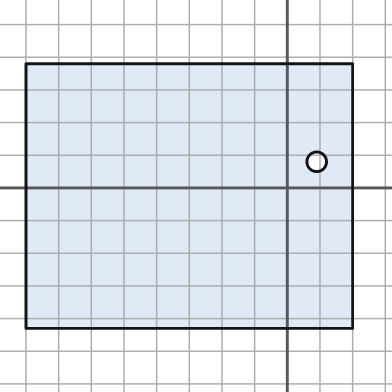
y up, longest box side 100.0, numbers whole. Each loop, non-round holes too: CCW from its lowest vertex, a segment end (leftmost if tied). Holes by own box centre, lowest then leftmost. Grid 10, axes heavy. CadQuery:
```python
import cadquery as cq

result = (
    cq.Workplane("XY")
    .moveTo(-80.0, -43.0)
    .lineTo(20.0, -43.0)
    .lineTo(20.0, 38.0)
    .lineTo(-80.0, 38.0)
    .close()
    .moveTo(9.0, 8.0)
    .circle(3.0)
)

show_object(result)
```